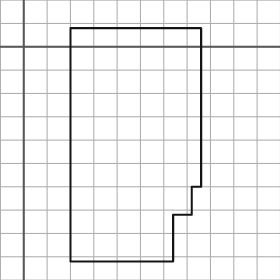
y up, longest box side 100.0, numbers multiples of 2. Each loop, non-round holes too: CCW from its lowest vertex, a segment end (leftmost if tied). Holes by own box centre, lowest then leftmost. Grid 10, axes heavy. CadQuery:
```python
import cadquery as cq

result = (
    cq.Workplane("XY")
    .moveTo(20.0, -92.0)
    .lineTo(64.0, -92.0)
    .lineTo(64.0, -72.0)
    .lineTo(72.0, -72.0)
    .lineTo(72.0, -60.0)
    .lineTo(76.0, -60.0)
    .lineTo(76.0, 8.0)
    .lineTo(20.0, 8.0)
    .close()
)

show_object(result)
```